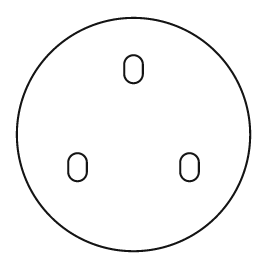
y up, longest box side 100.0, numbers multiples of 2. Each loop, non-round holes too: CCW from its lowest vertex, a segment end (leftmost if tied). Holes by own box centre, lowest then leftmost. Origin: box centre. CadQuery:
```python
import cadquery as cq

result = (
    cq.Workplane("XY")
    .moveTo(0.0, 0.0)
    .circle(50.0)
    .moveTo(-28.0, -16.0)
    .threePointArc((-24.0, -20.0), (-20.0, -16.0))
    .lineTo(-20.0, -12.0)
    .threePointArc((-24.0, -8.0), (-28.0, -12.0))
    .close()
    .moveTo(20.0, -16.0)
    .threePointArc((24.0, -20.0), (28.0, -16.0))
    .lineTo(28.0, -12.0)
    .threePointArc((24.0, -8.0), (20.0, -12.0))
    .close()
    .moveTo(-4.0, 26.0)
    .threePointArc((0.0, 22.0), (4.0, 26.0))
    .lineTo(4.0, 30.0)
    .threePointArc((0.0, 34.0), (-4.0, 30.0))
    .close()
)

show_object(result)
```